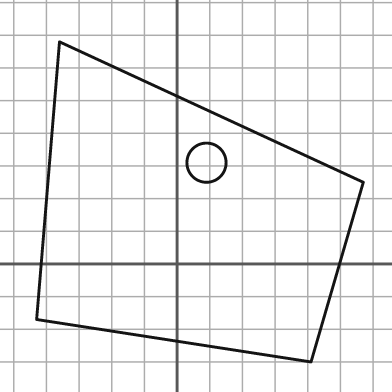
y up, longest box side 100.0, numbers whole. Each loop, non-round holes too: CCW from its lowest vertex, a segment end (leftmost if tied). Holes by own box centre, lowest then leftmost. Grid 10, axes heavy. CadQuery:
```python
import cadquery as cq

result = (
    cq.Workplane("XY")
    .moveTo(41.0, -30.0)
    .lineTo(57.0, 25.0)
    .lineTo(-36.0, 68.0)
    .lineTo(-43.0, -17.0)
    .close()
    .moveTo(9.0, 31.0)
    .circle(6.0)
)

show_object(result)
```